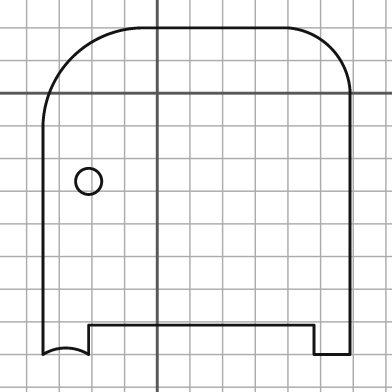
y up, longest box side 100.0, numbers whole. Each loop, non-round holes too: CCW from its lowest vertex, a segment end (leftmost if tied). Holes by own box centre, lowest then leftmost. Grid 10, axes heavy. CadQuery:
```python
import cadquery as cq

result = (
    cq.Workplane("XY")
    .moveTo(-35.0, -80.0)
    .threePointArc((-28.0, -78.0), (-21.0, -80.0))
    .lineTo(-21.0, -71.0)
    .lineTo(48.0, -71.0)
    .lineTo(48.0, -80.0)
    .lineTo(59.0, -80.0)
    .lineTo(59.0, 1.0)
    .threePointArc((53.0, 14.0), (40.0, 20.0))
    .lineTo(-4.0, 20.0)
    .threePointArc((-26.0, 11.0), (-35.0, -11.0))
    .close()
    .moveTo(-21.0, -27.0)
    .circle(4.0)
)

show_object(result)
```